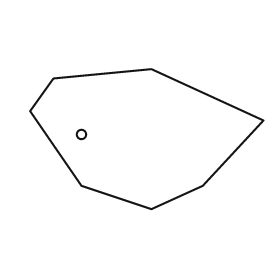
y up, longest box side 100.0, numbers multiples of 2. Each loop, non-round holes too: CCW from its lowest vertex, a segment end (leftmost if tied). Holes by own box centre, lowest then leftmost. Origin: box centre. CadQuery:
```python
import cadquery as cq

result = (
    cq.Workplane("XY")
    .moveTo(2.0, -30.0)
    .lineTo(24.0, -20.0)
    .lineTo(50.0, 8.0)
    .lineTo(2.0, 30.0)
    .lineTo(-40.0, 26.0)
    .lineTo(-50.0, 12.0)
    .lineTo(-28.0, -20.0)
    .close()
    .moveTo(-28.0, 2.0)
    .circle(2.0)
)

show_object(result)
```